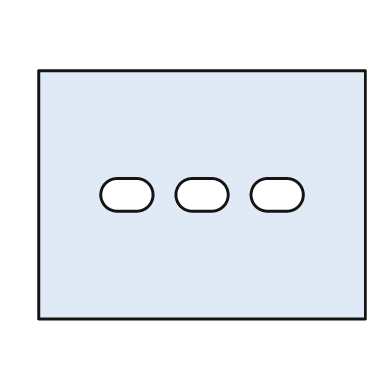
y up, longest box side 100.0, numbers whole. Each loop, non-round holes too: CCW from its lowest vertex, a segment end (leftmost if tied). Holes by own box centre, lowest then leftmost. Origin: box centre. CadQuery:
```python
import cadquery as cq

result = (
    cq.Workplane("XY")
    .moveTo(-50.0, -38.0)
    .lineTo(50.0, -38.0)
    .lineTo(50.0, 38.0)
    .lineTo(-50.0, 38.0)
    .close()
    .moveTo(-26.0, -5.0)
    .lineTo(-20.0, -5.0)
    .threePointArc((-15.0, 0.0), (-20.0, 5.0))
    .lineTo(-26.0, 5.0)
    .threePointArc((-31.0, 0.0), (-26.0, -5.0))
    .close()
    .moveTo(-3.0, -5.0)
    .lineTo(3.0, -5.0)
    .threePointArc((8.0, 0.0), (3.0, 5.0))
    .lineTo(-3.0, 5.0)
    .threePointArc((-8.0, 0.0), (-3.0, -5.0))
    .close()
    .moveTo(20.0, -5.0)
    .lineTo(26.0, -5.0)
    .threePointArc((31.0, 0.0), (26.0, 5.0))
    .lineTo(20.0, 5.0)
    .threePointArc((15.0, 0.0), (20.0, -5.0))
    .close()
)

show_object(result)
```